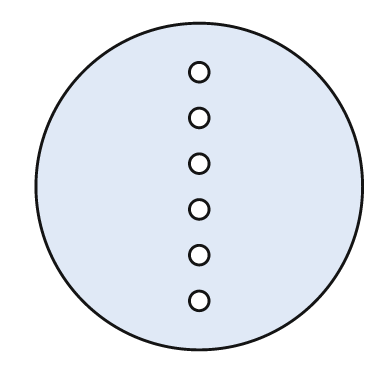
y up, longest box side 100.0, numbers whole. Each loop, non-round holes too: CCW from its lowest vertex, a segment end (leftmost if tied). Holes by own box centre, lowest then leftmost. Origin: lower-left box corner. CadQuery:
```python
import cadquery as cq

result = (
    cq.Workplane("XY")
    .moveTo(50.0, 50.0)
    .circle(50.0)
    .moveTo(50.0, 15.0)
    .circle(3.0)
    .moveTo(50.0, 29.0)
    .circle(3.0)
    .moveTo(50.0, 43.0)
    .circle(3.0)
    .moveTo(50.0, 57.0)
    .circle(3.0)
    .moveTo(50.0, 71.0)
    .circle(3.0)
    .moveTo(50.0, 85.0)
    .circle(3.0)
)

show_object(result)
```